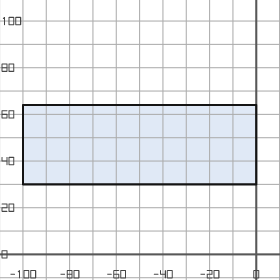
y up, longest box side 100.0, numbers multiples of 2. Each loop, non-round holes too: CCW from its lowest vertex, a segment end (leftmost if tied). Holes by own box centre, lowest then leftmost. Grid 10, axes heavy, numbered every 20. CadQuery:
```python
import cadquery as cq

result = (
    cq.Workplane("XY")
    .moveTo(-100.0, 30.0)
    .lineTo(0.0, 30.0)
    .lineTo(0.0, 64.0)
    .lineTo(-100.0, 64.0)
    .close()
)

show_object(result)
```